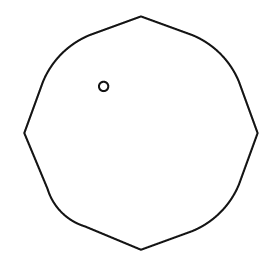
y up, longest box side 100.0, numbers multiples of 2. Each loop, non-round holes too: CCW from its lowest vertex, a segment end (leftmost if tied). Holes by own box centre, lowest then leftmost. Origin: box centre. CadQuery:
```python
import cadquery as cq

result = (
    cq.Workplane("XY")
    .moveTo(0.0, -50.0)
    .lineTo(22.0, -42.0)
    .threePointArc((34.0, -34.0), (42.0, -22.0))
    .lineTo(50.0, 0.0)
    .lineTo(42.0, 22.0)
    .threePointArc((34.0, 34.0), (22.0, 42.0))
    .lineTo(0.0, 50.0)
    .lineTo(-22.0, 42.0)
    .threePointArc((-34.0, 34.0), (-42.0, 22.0))
    .lineTo(-50.0, 0.0)
    .lineTo(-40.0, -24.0)
    .threePointArc((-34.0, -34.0), (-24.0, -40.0))
    .close()
    .moveTo(-16.0, 20.0)
    .circle(2.0)
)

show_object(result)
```